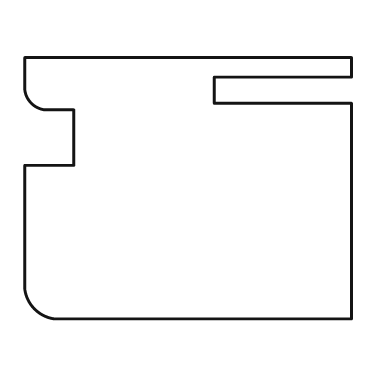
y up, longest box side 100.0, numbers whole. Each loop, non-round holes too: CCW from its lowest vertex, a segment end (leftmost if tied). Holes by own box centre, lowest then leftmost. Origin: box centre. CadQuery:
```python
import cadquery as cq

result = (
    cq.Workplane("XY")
    .moveTo(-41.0, -40.0)
    .lineTo(50.0, -40.0)
    .lineTo(50.0, 26.0)
    .lineTo(8.0, 26.0)
    .lineTo(8.0, 34.0)
    .lineTo(50.0, 34.0)
    .lineTo(50.0, 40.0)
    .lineTo(-50.0, 40.0)
    .lineTo(-50.0, 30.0)
    .threePointArc((-48.0, 26.0), (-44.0, 24.0))
    .lineTo(-35.0, 24.0)
    .lineTo(-35.0, 7.0)
    .lineTo(-50.0, 7.0)
    .lineTo(-50.0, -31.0)
    .threePointArc((-47.0, -37.0), (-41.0, -40.0))
    .close()
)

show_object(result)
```